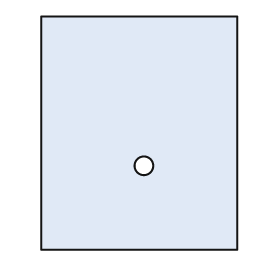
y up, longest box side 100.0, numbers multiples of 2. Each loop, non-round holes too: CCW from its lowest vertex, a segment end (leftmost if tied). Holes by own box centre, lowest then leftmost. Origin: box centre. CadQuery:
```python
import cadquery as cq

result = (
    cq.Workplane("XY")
    .moveTo(-42.0, -50.0)
    .lineTo(42.0, -50.0)
    .lineTo(42.0, 50.0)
    .lineTo(-42.0, 50.0)
    .close()
    .moveTo(2.0, -14.0)
    .circle(4.0)
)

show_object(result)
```